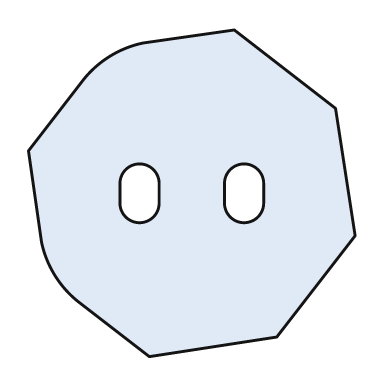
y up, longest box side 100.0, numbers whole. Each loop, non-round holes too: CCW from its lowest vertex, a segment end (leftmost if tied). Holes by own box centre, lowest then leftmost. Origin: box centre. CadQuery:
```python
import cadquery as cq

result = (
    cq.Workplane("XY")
    .moveTo(-13.0, -50.0)
    .lineTo(26.0, -44.0)
    .lineTo(50.0, -13.0)
    .lineTo(44.0, 26.0)
    .lineTo(13.0, 50.0)
    .lineTo(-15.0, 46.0)
    .threePointArc((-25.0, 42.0), (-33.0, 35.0))
    .lineTo(-50.0, 13.0)
    .lineTo(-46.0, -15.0)
    .threePointArc((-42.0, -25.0), (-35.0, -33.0))
    .close()
    .moveTo(-22.0, -3.0)
    .threePointArc((-16.0, -9.0), (-10.0, -3.0))
    .lineTo(-10.0, 3.0)
    .threePointArc((-16.0, 9.0), (-22.0, 3.0))
    .close()
    .moveTo(10.0, -3.0)
    .threePointArc((16.0, -9.0), (22.0, -3.0))
    .lineTo(22.0, 3.0)
    .threePointArc((16.0, 9.0), (10.0, 3.0))
    .close()
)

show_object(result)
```